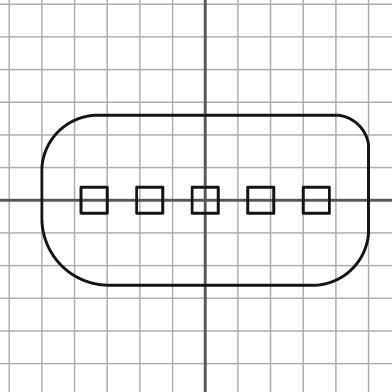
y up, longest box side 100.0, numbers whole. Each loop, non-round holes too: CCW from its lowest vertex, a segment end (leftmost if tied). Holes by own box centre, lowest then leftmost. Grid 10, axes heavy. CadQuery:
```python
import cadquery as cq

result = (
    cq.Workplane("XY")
    .moveTo(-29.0, -26.0)
    .lineTo(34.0, -26.0)
    .threePointArc((45.0, -21.0), (50.0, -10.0))
    .lineTo(50.0, 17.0)
    .threePointArc((47.0, 23.0), (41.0, 26.0))
    .lineTo(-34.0, 26.0)
    .threePointArc((-45.0, 21.0), (-50.0, 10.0))
    .lineTo(-50.0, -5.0)
    .threePointArc((-44.0, -20.0), (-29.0, -26.0))
    .close()
    .moveTo(-38.0, -4.0)
    .lineTo(-30.0, -4.0)
    .lineTo(-30.0, 4.0)
    .lineTo(-38.0, 4.0)
    .close()
    .moveTo(-21.0, -4.0)
    .lineTo(-13.0, -4.0)
    .lineTo(-13.0, 4.0)
    .lineTo(-21.0, 4.0)
    .close()
    .moveTo(-4.0, -4.0)
    .lineTo(4.0, -4.0)
    .lineTo(4.0, 4.0)
    .lineTo(-4.0, 4.0)
    .close()
    .moveTo(13.0, -4.0)
    .lineTo(21.0, -4.0)
    .lineTo(21.0, 4.0)
    .lineTo(13.0, 4.0)
    .close()
    .moveTo(30.0, -4.0)
    .lineTo(38.0, -4.0)
    .lineTo(38.0, 4.0)
    .lineTo(30.0, 4.0)
    .close()
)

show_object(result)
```